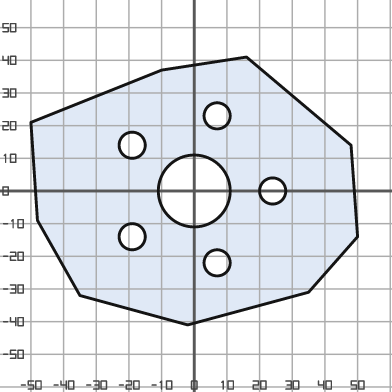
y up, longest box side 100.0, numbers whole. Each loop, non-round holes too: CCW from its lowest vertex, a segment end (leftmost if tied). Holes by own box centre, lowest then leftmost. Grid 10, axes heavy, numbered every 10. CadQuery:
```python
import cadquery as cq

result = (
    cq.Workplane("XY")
    .moveTo(-2.0, -41.0)
    .lineTo(35.0, -31.0)
    .lineTo(50.0, -14.0)
    .lineTo(48.0, 14.0)
    .lineTo(16.0, 41.0)
    .lineTo(-10.0, 37.0)
    .lineTo(-50.0, 21.0)
    .lineTo(-48.0, -9.0)
    .lineTo(-35.0, -32.0)
    .close()
    .moveTo(7.0, -22.0)
    .circle(4.0)
    .moveTo(-19.0, -14.0)
    .circle(4.0)
    .moveTo(0.0, 0.0)
    .circle(11.0)
    .moveTo(24.0, 0.0)
    .circle(4.0)
    .moveTo(-19.0, 14.0)
    .circle(4.0)
    .moveTo(7.0, 23.0)
    .circle(4.0)
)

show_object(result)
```